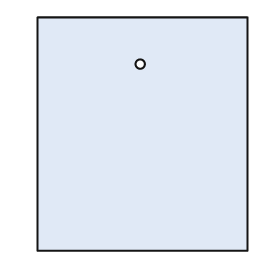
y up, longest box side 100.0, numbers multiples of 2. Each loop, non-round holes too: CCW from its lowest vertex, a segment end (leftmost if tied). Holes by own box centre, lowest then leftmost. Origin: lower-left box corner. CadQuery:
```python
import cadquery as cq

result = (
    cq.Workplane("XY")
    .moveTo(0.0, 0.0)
    .lineTo(90.0, 0.0)
    .lineTo(90.0, 100.0)
    .lineTo(0.0, 100.0)
    .close()
    .moveTo(44.0, 80.0)
    .circle(2.0)
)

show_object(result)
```